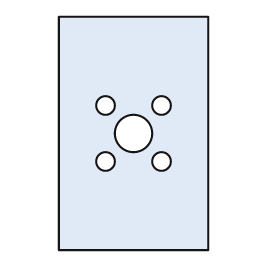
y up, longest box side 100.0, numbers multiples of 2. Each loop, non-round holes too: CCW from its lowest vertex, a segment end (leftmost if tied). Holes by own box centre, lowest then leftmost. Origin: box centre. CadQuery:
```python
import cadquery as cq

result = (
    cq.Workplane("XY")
    .moveTo(-32.0, -50.0)
    .lineTo(32.0, -50.0)
    .lineTo(32.0, 50.0)
    .lineTo(-32.0, 50.0)
    .close()
    .moveTo(-12.0, -12.0)
    .circle(4.0)
    .moveTo(12.0, -12.0)
    .circle(4.0)
    .moveTo(0.0, 0.0)
    .circle(8.0)
    .moveTo(-12.0, 12.0)
    .circle(4.0)
    .moveTo(12.0, 12.0)
    .circle(4.0)
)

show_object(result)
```